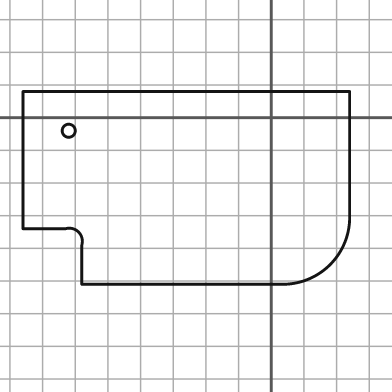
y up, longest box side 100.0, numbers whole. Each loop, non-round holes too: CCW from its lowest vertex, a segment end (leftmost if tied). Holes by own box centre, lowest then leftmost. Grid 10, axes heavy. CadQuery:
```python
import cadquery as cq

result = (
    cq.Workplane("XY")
    .moveTo(-58.0, -51.0)
    .lineTo(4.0, -51.0)
    .threePointArc((18.0, -45.0), (24.0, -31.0))
    .lineTo(24.0, 8.0)
    .lineTo(-76.0, 8.0)
    .lineTo(-76.0, -34.0)
    .lineTo(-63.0, -34.0)
    .threePointArc((-59.0, -35.0), (-58.0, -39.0))
    .close()
    .moveTo(-62.0, -4.0)
    .circle(2.0)
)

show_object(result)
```